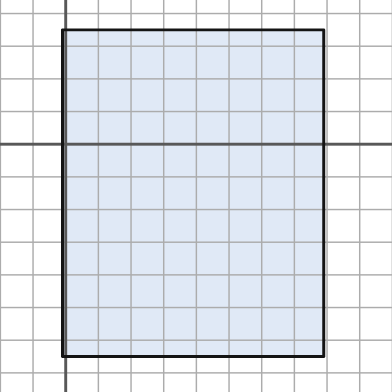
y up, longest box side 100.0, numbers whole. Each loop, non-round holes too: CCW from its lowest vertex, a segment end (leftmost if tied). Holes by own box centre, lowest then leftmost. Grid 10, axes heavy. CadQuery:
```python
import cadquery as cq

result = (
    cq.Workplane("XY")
    .moveTo(-1.0, -65.0)
    .lineTo(79.0, -65.0)
    .lineTo(79.0, 35.0)
    .lineTo(-1.0, 35.0)
    .close()
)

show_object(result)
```